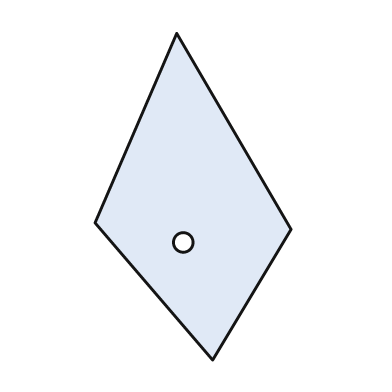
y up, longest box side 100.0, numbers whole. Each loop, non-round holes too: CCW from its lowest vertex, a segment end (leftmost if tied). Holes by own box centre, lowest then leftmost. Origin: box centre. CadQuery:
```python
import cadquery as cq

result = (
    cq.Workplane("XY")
    .moveTo(6.0, -50.0)
    .lineTo(30.0, -10.0)
    .lineTo(-5.0, 50.0)
    .lineTo(-30.0, -8.0)
    .close()
    .moveTo(-3.0, -14.0)
    .circle(3.0)
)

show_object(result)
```